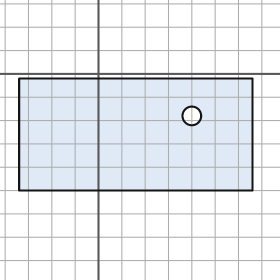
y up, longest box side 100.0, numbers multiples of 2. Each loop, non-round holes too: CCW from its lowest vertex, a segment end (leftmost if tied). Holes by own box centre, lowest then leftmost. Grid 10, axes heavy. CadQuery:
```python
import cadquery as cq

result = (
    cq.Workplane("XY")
    .moveTo(-34.0, -50.0)
    .lineTo(66.0, -50.0)
    .lineTo(66.0, -2.0)
    .lineTo(-34.0, -2.0)
    .close()
    .moveTo(40.0, -18.0)
    .circle(4.0)
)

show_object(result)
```